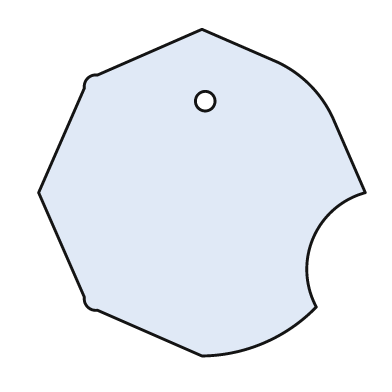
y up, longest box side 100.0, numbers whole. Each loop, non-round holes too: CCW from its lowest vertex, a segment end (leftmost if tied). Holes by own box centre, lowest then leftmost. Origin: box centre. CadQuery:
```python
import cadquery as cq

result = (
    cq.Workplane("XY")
    .moveTo(0.0, -50.0)
    .threePointArc((19.0, -46.0), (35.0, -35.0))
    .threePointArc((34.0, -14.0), (50.0, 0.0))
    .lineTo(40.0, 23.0)
    .threePointArc((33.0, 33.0), (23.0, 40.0))
    .lineTo(0.0, 50.0)
    .lineTo(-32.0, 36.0)
    .threePointArc((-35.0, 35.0), (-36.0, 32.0))
    .lineTo(-50.0, 0.0)
    .lineTo(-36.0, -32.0)
    .threePointArc((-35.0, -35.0), (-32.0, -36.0))
    .close()
    .moveTo(1.0, 28.0)
    .circle(3.0)
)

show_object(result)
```